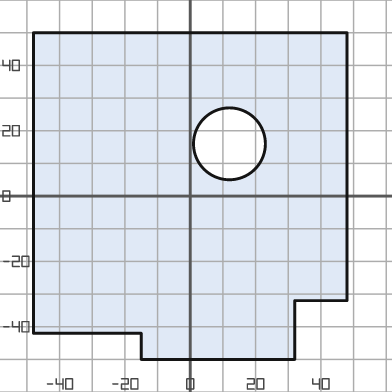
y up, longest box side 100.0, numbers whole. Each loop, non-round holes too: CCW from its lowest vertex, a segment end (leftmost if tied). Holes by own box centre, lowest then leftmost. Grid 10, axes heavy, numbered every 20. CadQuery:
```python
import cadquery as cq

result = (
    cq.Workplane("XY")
    .moveTo(-15.0, -50.0)
    .lineTo(32.0, -50.0)
    .lineTo(32.0, -32.0)
    .lineTo(48.0, -32.0)
    .lineTo(48.0, 50.0)
    .lineTo(-48.0, 50.0)
    .lineTo(-48.0, -42.0)
    .lineTo(-15.0, -42.0)
    .close()
    .moveTo(12.0, 16.0)
    .circle(11.0)
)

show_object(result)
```